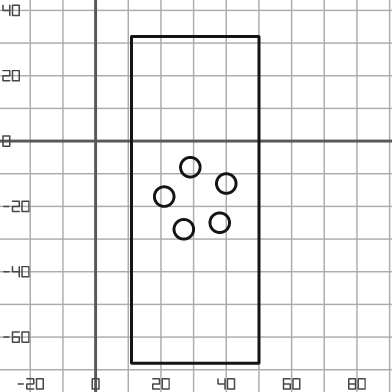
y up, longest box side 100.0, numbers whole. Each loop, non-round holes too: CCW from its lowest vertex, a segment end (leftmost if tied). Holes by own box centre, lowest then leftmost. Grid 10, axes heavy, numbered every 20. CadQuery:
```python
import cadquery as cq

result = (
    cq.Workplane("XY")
    .moveTo(11.0, -68.0)
    .lineTo(50.0, -68.0)
    .lineTo(50.0, 32.0)
    .lineTo(11.0, 32.0)
    .close()
    .moveTo(27.0, -27.0)
    .circle(3.0)
    .moveTo(38.0, -25.0)
    .circle(3.0)
    .moveTo(21.0, -17.0)
    .circle(3.0)
    .moveTo(40.0, -13.0)
    .circle(3.0)
    .moveTo(29.0, -8.0)
    .circle(3.0)
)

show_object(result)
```